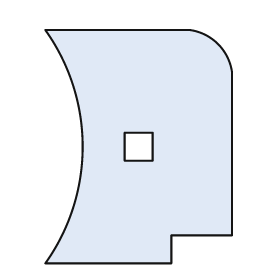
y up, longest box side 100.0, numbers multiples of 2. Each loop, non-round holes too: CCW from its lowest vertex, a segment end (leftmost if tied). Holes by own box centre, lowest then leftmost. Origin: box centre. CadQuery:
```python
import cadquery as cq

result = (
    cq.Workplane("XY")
    .moveTo(-40.0, -50.0)
    .lineTo(14.0, -50.0)
    .lineTo(14.0, -38.0)
    .lineTo(40.0, -38.0)
    .lineTo(40.0, 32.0)
    .threePointArc((34.0, 44.0), (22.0, 50.0))
    .lineTo(-40.0, 50.0)
    .threePointArc((-24.0, 0.0), (-40.0, -50.0))
    .close()
    .moveTo(-6.0, -6.0)
    .lineTo(6.0, -6.0)
    .lineTo(6.0, 6.0)
    .lineTo(-6.0, 6.0)
    .close()
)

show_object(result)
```